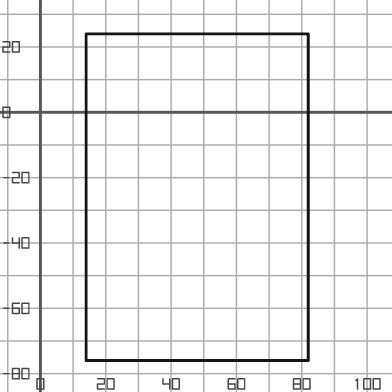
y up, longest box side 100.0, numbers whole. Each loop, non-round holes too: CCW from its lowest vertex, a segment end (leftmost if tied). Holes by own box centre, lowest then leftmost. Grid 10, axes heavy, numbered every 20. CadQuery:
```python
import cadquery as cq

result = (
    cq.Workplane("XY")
    .moveTo(14.0, -76.0)
    .lineTo(82.0, -76.0)
    .lineTo(82.0, 24.0)
    .lineTo(14.0, 24.0)
    .close()
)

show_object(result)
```